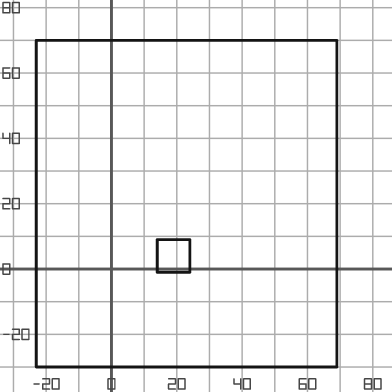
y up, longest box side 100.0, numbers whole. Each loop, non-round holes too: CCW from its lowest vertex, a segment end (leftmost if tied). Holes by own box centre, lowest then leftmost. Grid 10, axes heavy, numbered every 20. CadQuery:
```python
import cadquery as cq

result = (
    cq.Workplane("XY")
    .moveTo(-23.0, -30.0)
    .lineTo(69.0, -30.0)
    .lineTo(69.0, 70.0)
    .lineTo(-23.0, 70.0)
    .close()
    .moveTo(14.0, -1.0)
    .lineTo(24.0, -1.0)
    .lineTo(24.0, 9.0)
    .lineTo(14.0, 9.0)
    .close()
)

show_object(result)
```